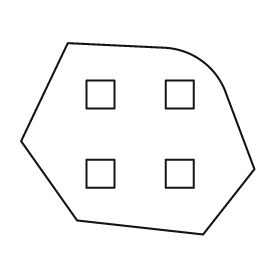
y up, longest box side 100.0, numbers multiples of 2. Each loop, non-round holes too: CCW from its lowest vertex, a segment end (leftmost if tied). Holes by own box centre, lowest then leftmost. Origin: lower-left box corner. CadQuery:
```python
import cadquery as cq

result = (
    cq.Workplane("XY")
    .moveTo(78.0, 0.0)
    .lineTo(100.0, 28.0)
    .lineTo(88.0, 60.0)
    .threePointArc((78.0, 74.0), (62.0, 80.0))
    .lineTo(20.0, 82.0)
    .lineTo(0.0, 40.0)
    .lineTo(24.0, 6.0)
    .close()
    .moveTo(28.0, 20.0)
    .lineTo(40.0, 20.0)
    .lineTo(40.0, 32.0)
    .lineTo(28.0, 32.0)
    .close()
    .moveTo(62.0, 20.0)
    .lineTo(74.0, 20.0)
    .lineTo(74.0, 32.0)
    .lineTo(62.0, 32.0)
    .close()
    .moveTo(28.0, 54.0)
    .lineTo(40.0, 54.0)
    .lineTo(40.0, 66.0)
    .lineTo(28.0, 66.0)
    .close()
    .moveTo(62.0, 54.0)
    .lineTo(74.0, 54.0)
    .lineTo(74.0, 66.0)
    .lineTo(62.0, 66.0)
    .close()
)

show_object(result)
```